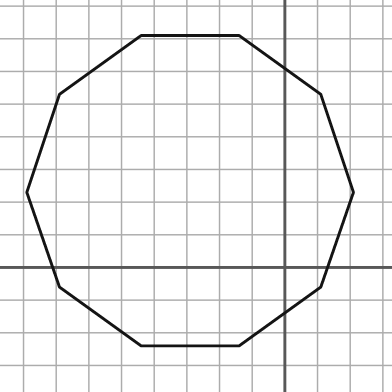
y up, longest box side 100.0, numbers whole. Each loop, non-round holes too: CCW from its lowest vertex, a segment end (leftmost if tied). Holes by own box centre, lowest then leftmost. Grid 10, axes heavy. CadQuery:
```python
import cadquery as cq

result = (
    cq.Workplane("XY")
    .moveTo(-44.0, -24.0)
    .lineTo(-14.0, -24.0)
    .lineTo(11.0, -6.0)
    .lineTo(21.0, 23.0)
    .lineTo(11.0, 53.0)
    .lineTo(-14.0, 71.0)
    .lineTo(-44.0, 71.0)
    .lineTo(-69.0, 53.0)
    .lineTo(-79.0, 23.0)
    .lineTo(-69.0, -6.0)
    .close()
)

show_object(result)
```